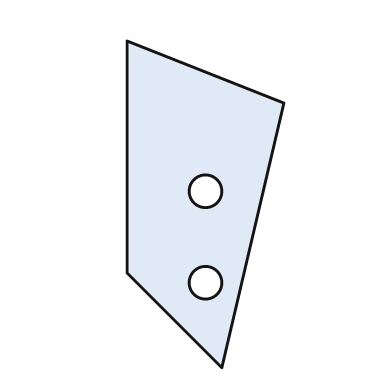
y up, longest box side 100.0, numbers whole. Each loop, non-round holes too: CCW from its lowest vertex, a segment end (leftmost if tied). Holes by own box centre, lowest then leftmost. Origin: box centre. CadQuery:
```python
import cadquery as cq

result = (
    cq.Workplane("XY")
    .moveTo(5.0, -50.0)
    .lineTo(24.0, 31.0)
    .lineTo(-24.0, 50.0)
    .lineTo(-24.0, -21.0)
    .close()
    .moveTo(0.0, -24.0)
    .circle(5.0)
    .moveTo(0.0, 4.0)
    .circle(5.0)
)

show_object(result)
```